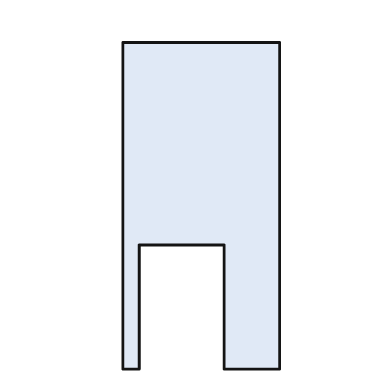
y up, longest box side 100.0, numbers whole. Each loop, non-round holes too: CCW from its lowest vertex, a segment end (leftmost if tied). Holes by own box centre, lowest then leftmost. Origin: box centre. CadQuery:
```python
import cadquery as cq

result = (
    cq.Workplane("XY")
    .moveTo(-24.0, -50.0)
    .lineTo(-19.0, -50.0)
    .lineTo(-19.0, -12.0)
    .lineTo(7.0, -12.0)
    .lineTo(7.0, -50.0)
    .lineTo(24.0, -50.0)
    .lineTo(24.0, 50.0)
    .lineTo(-24.0, 50.0)
    .close()
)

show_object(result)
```